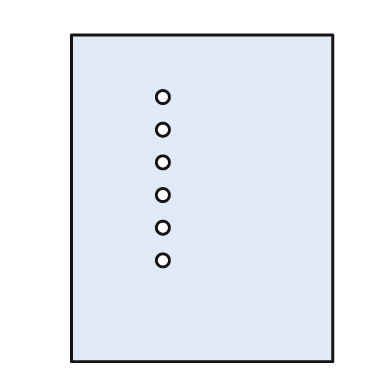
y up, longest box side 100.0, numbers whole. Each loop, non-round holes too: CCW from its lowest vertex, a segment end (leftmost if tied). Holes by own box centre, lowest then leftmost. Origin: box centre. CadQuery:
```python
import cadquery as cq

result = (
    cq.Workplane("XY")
    .moveTo(-40.0, -50.0)
    .lineTo(40.0, -50.0)
    .lineTo(40.0, 50.0)
    .lineTo(-40.0, 50.0)
    .close()
    .moveTo(-12.0, -19.0)
    .circle(2.0)
    .moveTo(-12.0, -9.0)
    .circle(2.0)
    .moveTo(-12.0, 1.0)
    .circle(2.0)
    .moveTo(-12.0, 11.0)
    .circle(2.0)
    .moveTo(-12.0, 21.0)
    .circle(2.0)
    .moveTo(-12.0, 31.0)
    .circle(2.0)
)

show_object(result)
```